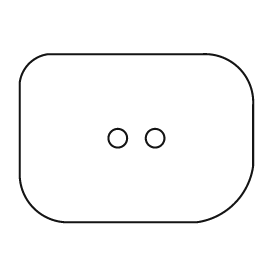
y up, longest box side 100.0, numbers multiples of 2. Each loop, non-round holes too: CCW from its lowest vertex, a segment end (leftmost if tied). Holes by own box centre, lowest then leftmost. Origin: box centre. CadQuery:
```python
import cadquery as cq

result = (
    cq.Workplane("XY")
    .moveTo(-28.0, -36.0)
    .lineTo(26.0, -36.0)
    .threePointArc((42.0, -28.0), (50.0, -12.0))
    .lineTo(50.0, 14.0)
    .threePointArc((44.0, 30.0), (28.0, 36.0))
    .lineTo(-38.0, 36.0)
    .threePointArc((-46.0, 32.0), (-50.0, 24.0))
    .lineTo(-50.0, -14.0)
    .threePointArc((-44.0, -30.0), (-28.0, -36.0))
    .close()
    .moveTo(-8.0, 0.0)
    .circle(4.0)
    .moveTo(8.0, 0.0)
    .circle(4.0)
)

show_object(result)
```